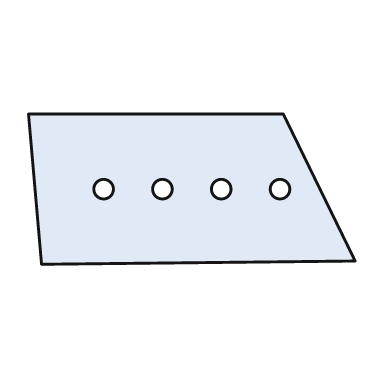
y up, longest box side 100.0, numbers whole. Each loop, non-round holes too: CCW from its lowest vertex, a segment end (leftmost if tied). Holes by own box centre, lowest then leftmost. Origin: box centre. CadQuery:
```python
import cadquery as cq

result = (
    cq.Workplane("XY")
    .moveTo(-46.0, -23.0)
    .lineTo(50.0, -22.0)
    .lineTo(28.0, 23.0)
    .lineTo(-50.0, 23.0)
    .close()
    .moveTo(-27.0, 0.0)
    .circle(3.0)
    .moveTo(-9.0, 0.0)
    .circle(3.0)
    .moveTo(9.0, 0.0)
    .circle(3.0)
    .moveTo(27.0, 0.0)
    .circle(3.0)
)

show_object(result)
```